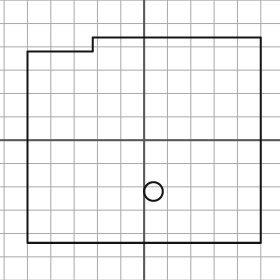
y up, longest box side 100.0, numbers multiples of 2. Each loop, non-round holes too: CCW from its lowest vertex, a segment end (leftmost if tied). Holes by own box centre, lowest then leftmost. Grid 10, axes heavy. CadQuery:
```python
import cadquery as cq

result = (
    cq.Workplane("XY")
    .moveTo(-50.0, -44.0)
    .lineTo(50.0, -44.0)
    .lineTo(50.0, 44.0)
    .lineTo(-22.0, 44.0)
    .lineTo(-22.0, 38.0)
    .lineTo(-50.0, 38.0)
    .close()
    .moveTo(4.0, -22.0)
    .circle(4.0)
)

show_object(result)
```